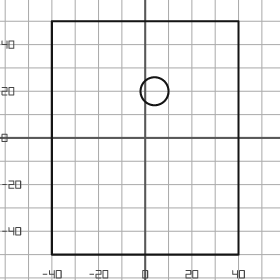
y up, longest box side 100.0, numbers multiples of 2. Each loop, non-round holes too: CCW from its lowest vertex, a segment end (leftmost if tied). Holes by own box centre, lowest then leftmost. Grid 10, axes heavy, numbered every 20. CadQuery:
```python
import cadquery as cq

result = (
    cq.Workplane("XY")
    .moveTo(-40.0, -50.0)
    .lineTo(40.0, -50.0)
    .lineTo(40.0, 50.0)
    .lineTo(-40.0, 50.0)
    .close()
    .moveTo(4.0, 20.0)
    .circle(6.0)
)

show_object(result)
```